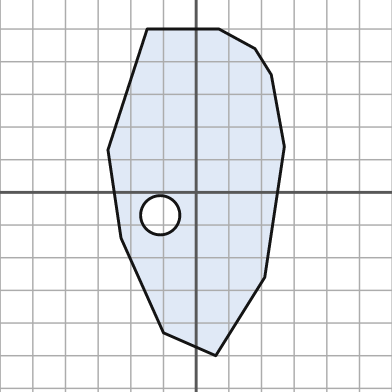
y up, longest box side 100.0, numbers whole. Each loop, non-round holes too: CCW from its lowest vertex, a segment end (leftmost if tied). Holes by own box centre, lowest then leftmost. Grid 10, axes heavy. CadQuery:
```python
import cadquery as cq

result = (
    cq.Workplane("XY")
    .moveTo(6.0, -50.0)
    .lineTo(21.0, -26.0)
    .lineTo(27.0, 14.0)
    .lineTo(23.0, 36.0)
    .lineTo(18.0, 44.0)
    .lineTo(7.0, 50.0)
    .lineTo(-15.0, 50.0)
    .lineTo(-27.0, 13.0)
    .lineTo(-23.0, -14.0)
    .lineTo(-10.0, -43.0)
    .close()
    .moveTo(-11.0, -7.0)
    .circle(6.0)
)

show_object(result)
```